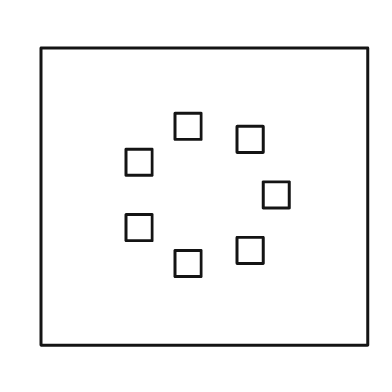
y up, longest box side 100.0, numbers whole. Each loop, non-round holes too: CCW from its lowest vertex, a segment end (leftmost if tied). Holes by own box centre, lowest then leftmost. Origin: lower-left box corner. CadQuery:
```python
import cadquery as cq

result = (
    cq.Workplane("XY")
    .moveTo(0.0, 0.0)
    .lineTo(100.0, 0.0)
    .lineTo(100.0, 91.0)
    .lineTo(0.0, 91.0)
    .close()
    .moveTo(41.0, 21.0)
    .lineTo(49.0, 21.0)
    .lineTo(49.0, 29.0)
    .lineTo(41.0, 29.0)
    .close()
    .moveTo(60.0, 25.0)
    .lineTo(68.0, 25.0)
    .lineTo(68.0, 33.0)
    .lineTo(60.0, 33.0)
    .close()
    .moveTo(26.0, 32.0)
    .lineTo(34.0, 32.0)
    .lineTo(34.0, 40.0)
    .lineTo(26.0, 40.0)
    .close()
    .moveTo(68.0, 42.0)
    .lineTo(76.0, 42.0)
    .lineTo(76.0, 50.0)
    .lineTo(68.0, 50.0)
    .close()
    .moveTo(26.0, 52.0)
    .lineTo(34.0, 52.0)
    .lineTo(34.0, 60.0)
    .lineTo(26.0, 60.0)
    .close()
    .moveTo(60.0, 59.0)
    .lineTo(68.0, 59.0)
    .lineTo(68.0, 67.0)
    .lineTo(60.0, 67.0)
    .close()
    .moveTo(41.0, 63.0)
    .lineTo(49.0, 63.0)
    .lineTo(49.0, 71.0)
    .lineTo(41.0, 71.0)
    .close()
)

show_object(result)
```